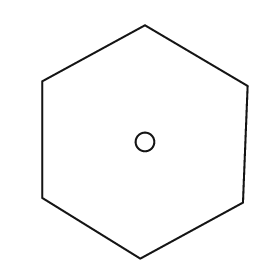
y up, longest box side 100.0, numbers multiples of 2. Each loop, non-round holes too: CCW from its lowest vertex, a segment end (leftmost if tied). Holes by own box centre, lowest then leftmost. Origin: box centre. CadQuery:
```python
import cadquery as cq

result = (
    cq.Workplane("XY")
    .moveTo(-2.0, -50.0)
    .lineTo(42.0, -26.0)
    .lineTo(44.0, 24.0)
    .lineTo(0.0, 50.0)
    .lineTo(-44.0, 26.0)
    .lineTo(-44.0, -24.0)
    .close()
    .moveTo(0.0, 0.0)
    .circle(4.0)
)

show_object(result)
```